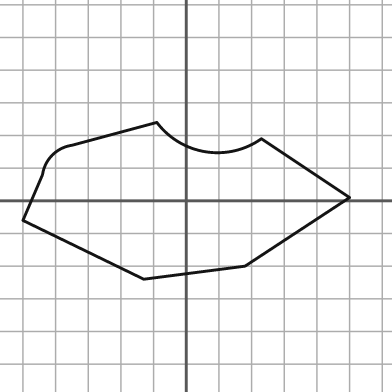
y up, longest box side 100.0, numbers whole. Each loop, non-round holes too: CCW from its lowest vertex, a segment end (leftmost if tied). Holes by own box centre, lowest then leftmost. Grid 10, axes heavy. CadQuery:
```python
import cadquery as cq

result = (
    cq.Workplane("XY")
    .moveTo(-13.0, -24.0)
    .lineTo(18.0, -20.0)
    .lineTo(50.0, 1.0)
    .lineTo(23.0, 19.0)
    .threePointArc((6.0, 15.0), (-9.0, 24.0))
    .lineTo(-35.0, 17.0)
    .threePointArc((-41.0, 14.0), (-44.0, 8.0))
    .lineTo(-50.0, -6.0)
    .close()
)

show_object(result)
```